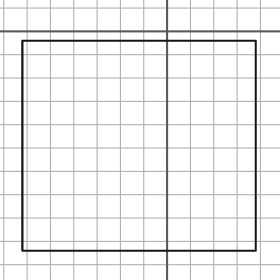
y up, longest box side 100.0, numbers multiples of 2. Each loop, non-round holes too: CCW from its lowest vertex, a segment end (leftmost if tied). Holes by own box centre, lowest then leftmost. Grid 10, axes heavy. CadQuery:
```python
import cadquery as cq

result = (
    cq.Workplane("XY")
    .moveTo(-62.0, -94.0)
    .lineTo(38.0, -94.0)
    .lineTo(38.0, -4.0)
    .lineTo(-62.0, -4.0)
    .close()
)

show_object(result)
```